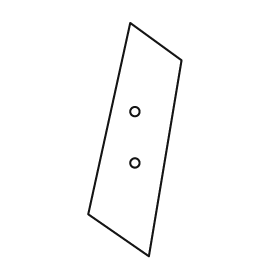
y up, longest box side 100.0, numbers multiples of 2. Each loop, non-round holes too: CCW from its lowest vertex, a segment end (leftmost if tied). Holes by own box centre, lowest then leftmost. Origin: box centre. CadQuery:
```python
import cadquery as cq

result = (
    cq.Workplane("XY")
    .moveTo(6.0, -50.0)
    .lineTo(20.0, 34.0)
    .lineTo(-2.0, 50.0)
    .lineTo(-20.0, -32.0)
    .close()
    .moveTo(0.0, -10.0)
    .circle(2.0)
    .moveTo(0.0, 12.0)
    .circle(2.0)
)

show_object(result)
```